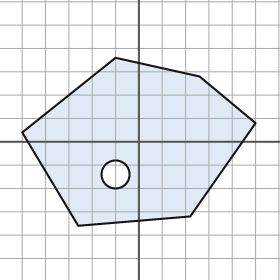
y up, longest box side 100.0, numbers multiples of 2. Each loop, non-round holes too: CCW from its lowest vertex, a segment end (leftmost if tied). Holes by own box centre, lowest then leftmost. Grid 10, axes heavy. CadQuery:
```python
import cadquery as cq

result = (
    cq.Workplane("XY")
    .moveTo(-26.0, -36.0)
    .lineTo(22.0, -32.0)
    .lineTo(50.0, 8.0)
    .lineTo(26.0, 28.0)
    .lineTo(-10.0, 36.0)
    .lineTo(-50.0, 4.0)
    .close()
    .moveTo(-10.0, -14.0)
    .circle(6.0)
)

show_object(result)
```